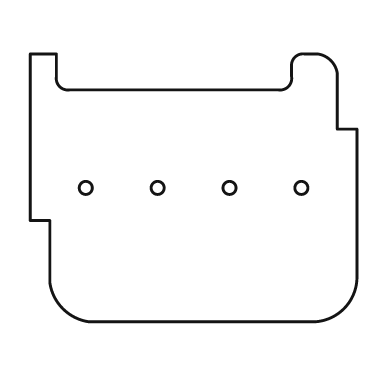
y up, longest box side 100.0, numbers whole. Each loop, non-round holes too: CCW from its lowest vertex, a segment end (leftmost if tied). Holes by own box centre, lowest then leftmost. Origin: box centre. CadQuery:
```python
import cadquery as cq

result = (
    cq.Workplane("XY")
    .moveTo(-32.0, -41.0)
    .lineTo(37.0, -41.0)
    .threePointArc((46.0, -37.0), (50.0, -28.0))
    .lineTo(50.0, 18.0)
    .lineTo(44.0, 18.0)
    .lineTo(44.0, 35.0)
    .threePointArc((42.0, 39.0), (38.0, 41.0))
    .lineTo(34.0, 41.0)
    .threePointArc((31.0, 40.0), (30.0, 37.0))
    .lineTo(30.0, 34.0)
    .threePointArc((29.0, 31.0), (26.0, 30.0))
    .lineTo(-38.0, 30.0)
    .threePointArc((-41.0, 31.0), (-42.0, 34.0))
    .lineTo(-42.0, 41.0)
    .lineTo(-50.0, 41.0)
    .lineTo(-50.0, -10.0)
    .lineTo(-44.0, -10.0)
    .lineTo(-44.0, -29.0)
    .threePointArc((-40.0, -37.0), (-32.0, -41.0))
    .close()
    .moveTo(-33.0, 0.0)
    .circle(2.0)
    .moveTo(-11.0, 0.0)
    .circle(2.0)
    .moveTo(11.0, 0.0)
    .circle(2.0)
    .moveTo(33.0, 0.0)
    .circle(2.0)
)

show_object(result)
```